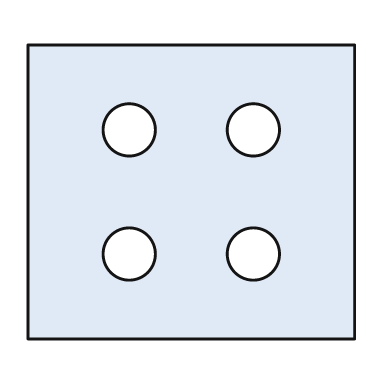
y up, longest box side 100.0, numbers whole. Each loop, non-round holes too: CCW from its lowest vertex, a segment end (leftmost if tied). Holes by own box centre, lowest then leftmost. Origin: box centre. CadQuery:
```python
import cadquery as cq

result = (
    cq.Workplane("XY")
    .moveTo(-50.0, -45.0)
    .lineTo(50.0, -45.0)
    .lineTo(50.0, 45.0)
    .lineTo(-50.0, 45.0)
    .close()
    .moveTo(-19.0, -19.0)
    .circle(8.0)
    .moveTo(19.0, -19.0)
    .circle(8.0)
    .moveTo(-19.0, 19.0)
    .circle(8.0)
    .moveTo(19.0, 19.0)
    .circle(8.0)
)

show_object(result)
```